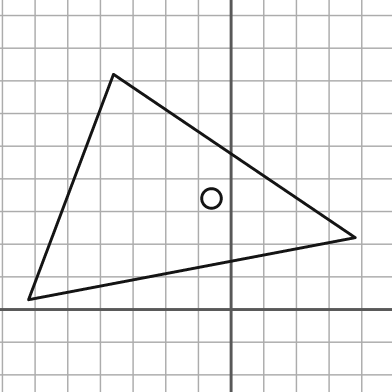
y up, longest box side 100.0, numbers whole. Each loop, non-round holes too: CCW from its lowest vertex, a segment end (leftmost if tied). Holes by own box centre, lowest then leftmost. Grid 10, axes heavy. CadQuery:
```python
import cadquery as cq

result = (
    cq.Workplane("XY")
    .moveTo(-62.0, 3.0)
    .lineTo(38.0, 22.0)
    .lineTo(-36.0, 72.0)
    .close()
    .moveTo(-6.0, 34.0)
    .circle(3.0)
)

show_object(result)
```